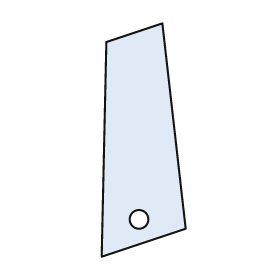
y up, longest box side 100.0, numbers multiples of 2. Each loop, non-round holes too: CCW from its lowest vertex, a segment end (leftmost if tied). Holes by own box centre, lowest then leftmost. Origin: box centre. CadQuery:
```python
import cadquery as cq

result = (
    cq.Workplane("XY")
    .moveTo(-18.0, -50.0)
    .lineTo(18.0, -38.0)
    .lineTo(8.0, 50.0)
    .lineTo(-16.0, 42.0)
    .close()
    .moveTo(-2.0, -34.0)
    .circle(4.0)
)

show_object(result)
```